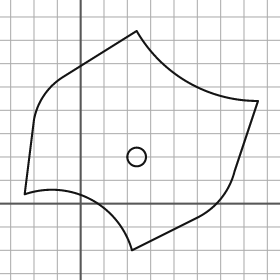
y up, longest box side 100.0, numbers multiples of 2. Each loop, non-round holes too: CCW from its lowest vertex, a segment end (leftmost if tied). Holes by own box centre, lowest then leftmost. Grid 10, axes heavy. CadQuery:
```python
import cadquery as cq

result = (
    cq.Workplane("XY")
    .moveTo(22.0, -20.0)
    .lineTo(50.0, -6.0)
    .threePointArc((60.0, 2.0), (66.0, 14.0))
    .lineTo(76.0, 44.0)
    .threePointArc((46.0, 52.0), (24.0, 74.0))
    .lineTo(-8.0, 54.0)
    .threePointArc((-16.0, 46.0), (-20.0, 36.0))
    .lineTo(-24.0, 4.0)
    .threePointArc((4.0, 2.0), (22.0, -20.0))
    .close()
    .moveTo(24.0, 20.0)
    .circle(4.0)
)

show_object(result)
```